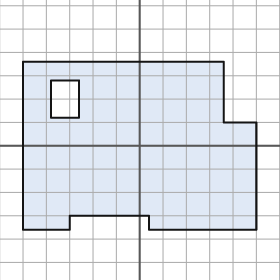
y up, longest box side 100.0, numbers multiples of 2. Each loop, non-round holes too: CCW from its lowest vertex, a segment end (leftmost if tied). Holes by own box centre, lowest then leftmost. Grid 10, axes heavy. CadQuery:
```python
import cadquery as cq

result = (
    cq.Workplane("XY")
    .moveTo(-50.0, -36.0)
    .lineTo(-30.0, -36.0)
    .lineTo(-30.0, -30.0)
    .lineTo(4.0, -30.0)
    .lineTo(4.0, -36.0)
    .lineTo(50.0, -36.0)
    .lineTo(50.0, 10.0)
    .lineTo(36.0, 10.0)
    .lineTo(36.0, 36.0)
    .lineTo(-50.0, 36.0)
    .close()
    .moveTo(-38.0, 12.0)
    .lineTo(-26.0, 12.0)
    .lineTo(-26.0, 28.0)
    .lineTo(-38.0, 28.0)
    .close()
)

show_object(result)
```